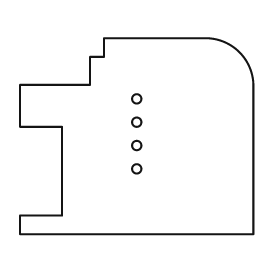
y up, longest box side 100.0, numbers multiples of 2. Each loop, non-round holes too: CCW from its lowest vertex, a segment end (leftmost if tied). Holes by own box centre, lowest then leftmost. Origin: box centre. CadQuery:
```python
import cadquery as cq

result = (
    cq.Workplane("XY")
    .moveTo(-50.0, -42.0)
    .lineTo(50.0, -42.0)
    .lineTo(50.0, 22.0)
    .threePointArc((44.0, 36.0), (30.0, 42.0))
    .lineTo(-14.0, 42.0)
    .lineTo(-14.0, 34.0)
    .lineTo(-20.0, 34.0)
    .lineTo(-20.0, 22.0)
    .lineTo(-50.0, 22.0)
    .lineTo(-50.0, 4.0)
    .lineTo(-32.0, 4.0)
    .lineTo(-32.0, -34.0)
    .lineTo(-50.0, -34.0)
    .close()
    .moveTo(0.0, -14.0)
    .circle(2.0)
    .moveTo(0.0, -4.0)
    .circle(2.0)
    .moveTo(0.0, 6.0)
    .circle(2.0)
    .moveTo(0.0, 16.0)
    .circle(2.0)
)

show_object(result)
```